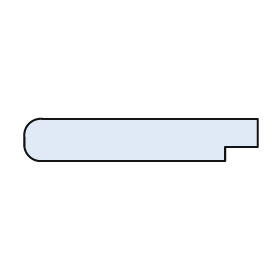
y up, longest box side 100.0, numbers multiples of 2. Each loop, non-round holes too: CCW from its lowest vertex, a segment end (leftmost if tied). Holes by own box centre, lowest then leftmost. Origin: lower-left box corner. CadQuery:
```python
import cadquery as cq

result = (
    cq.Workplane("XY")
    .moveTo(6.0, 0.0)
    .lineTo(86.0, 0.0)
    .lineTo(86.0, 6.0)
    .lineTo(100.0, 6.0)
    .lineTo(100.0, 18.0)
    .lineTo(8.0, 18.0)
    .threePointArc((2.0, 16.0), (0.0, 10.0))
    .lineTo(0.0, 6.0)
    .threePointArc((2.0, 2.0), (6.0, 0.0))
    .close()
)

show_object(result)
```